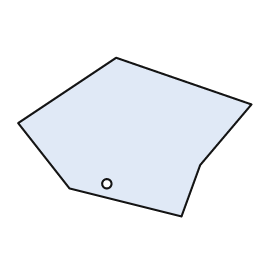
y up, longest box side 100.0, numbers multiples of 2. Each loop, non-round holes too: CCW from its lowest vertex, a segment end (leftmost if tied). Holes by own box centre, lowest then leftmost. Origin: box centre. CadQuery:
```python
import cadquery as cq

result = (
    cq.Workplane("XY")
    .moveTo(20.0, -34.0)
    .lineTo(28.0, -12.0)
    .lineTo(50.0, 14.0)
    .lineTo(-8.0, 34.0)
    .lineTo(-50.0, 6.0)
    .lineTo(-28.0, -22.0)
    .close()
    .moveTo(-12.0, -20.0)
    .circle(2.0)
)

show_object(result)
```